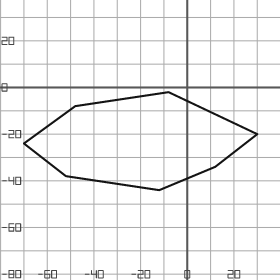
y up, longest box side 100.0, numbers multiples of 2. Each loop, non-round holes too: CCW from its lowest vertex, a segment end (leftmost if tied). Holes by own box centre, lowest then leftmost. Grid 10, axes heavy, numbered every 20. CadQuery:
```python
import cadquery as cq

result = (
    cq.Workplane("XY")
    .moveTo(-12.0, -44.0)
    .lineTo(12.0, -34.0)
    .lineTo(30.0, -20.0)
    .lineTo(-8.0, -2.0)
    .lineTo(-48.0, -8.0)
    .lineTo(-70.0, -24.0)
    .lineTo(-52.0, -38.0)
    .close()
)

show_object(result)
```